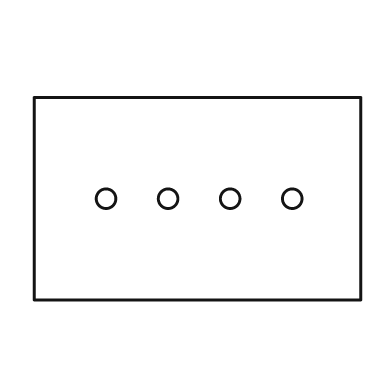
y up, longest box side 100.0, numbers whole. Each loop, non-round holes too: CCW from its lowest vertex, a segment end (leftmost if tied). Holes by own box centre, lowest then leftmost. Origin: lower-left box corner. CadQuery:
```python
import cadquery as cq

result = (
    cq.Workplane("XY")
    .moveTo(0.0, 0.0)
    .lineTo(100.0, 0.0)
    .lineTo(100.0, 62.0)
    .lineTo(0.0, 62.0)
    .close()
    .moveTo(22.0, 31.0)
    .circle(3.0)
    .moveTo(41.0, 31.0)
    .circle(3.0)
    .moveTo(60.0, 31.0)
    .circle(3.0)
    .moveTo(79.0, 31.0)
    .circle(3.0)
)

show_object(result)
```